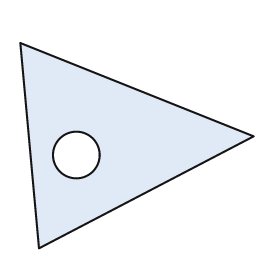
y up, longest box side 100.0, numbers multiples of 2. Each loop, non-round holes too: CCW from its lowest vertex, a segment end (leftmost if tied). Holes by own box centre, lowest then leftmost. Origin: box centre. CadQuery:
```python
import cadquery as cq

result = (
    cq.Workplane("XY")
    .moveTo(-42.0, -44.0)
    .lineTo(50.0, 4.0)
    .lineTo(-50.0, 44.0)
    .close()
    .moveTo(-26.0, -4.0)
    .circle(10.0)
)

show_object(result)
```